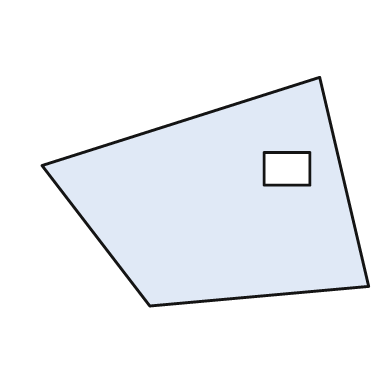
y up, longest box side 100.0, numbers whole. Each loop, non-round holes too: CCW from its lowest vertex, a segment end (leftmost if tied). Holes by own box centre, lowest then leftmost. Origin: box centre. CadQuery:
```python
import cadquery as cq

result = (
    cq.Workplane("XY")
    .moveTo(-17.0, -35.0)
    .lineTo(50.0, -29.0)
    .lineTo(35.0, 35.0)
    .lineTo(-50.0, 8.0)
    .close()
    .moveTo(18.0, 2.0)
    .lineTo(32.0, 2.0)
    .lineTo(32.0, 12.0)
    .lineTo(18.0, 12.0)
    .close()
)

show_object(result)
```